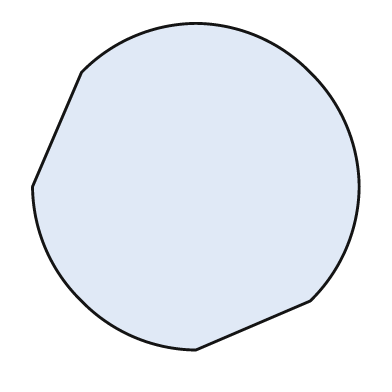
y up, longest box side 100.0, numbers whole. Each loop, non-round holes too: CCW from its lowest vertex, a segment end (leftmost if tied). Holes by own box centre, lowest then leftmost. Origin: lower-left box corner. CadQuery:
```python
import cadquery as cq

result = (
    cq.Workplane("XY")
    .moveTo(50.0, 0.0)
    .lineTo(85.0, 15.0)
    .threePointArc((96.0, 31.0), (100.0, 50.0))
    .threePointArc((96.0, 69.0), (85.0, 85.0))
    .threePointArc((69.0, 96.0), (50.0, 100.0))
    .threePointArc((31.0, 96.0), (15.0, 85.0))
    .lineTo(0.0, 50.0)
    .threePointArc((4.0, 31.0), (15.0, 15.0))
    .threePointArc((31.0, 4.0), (50.0, 0.0))
    .close()
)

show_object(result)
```